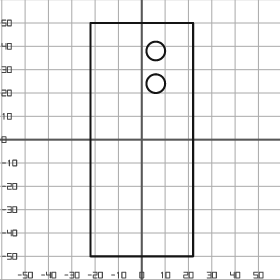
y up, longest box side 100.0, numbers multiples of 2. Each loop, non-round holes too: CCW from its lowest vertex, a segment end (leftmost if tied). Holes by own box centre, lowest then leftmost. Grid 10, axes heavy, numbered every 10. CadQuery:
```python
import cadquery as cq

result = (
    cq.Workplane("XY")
    .moveTo(-22.0, -50.0)
    .lineTo(22.0, -50.0)
    .lineTo(22.0, 50.0)
    .lineTo(-22.0, 50.0)
    .close()
    .moveTo(6.0, 24.0)
    .circle(4.0)
    .moveTo(6.0, 38.0)
    .circle(4.0)
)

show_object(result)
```